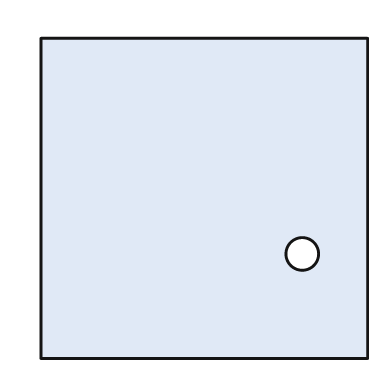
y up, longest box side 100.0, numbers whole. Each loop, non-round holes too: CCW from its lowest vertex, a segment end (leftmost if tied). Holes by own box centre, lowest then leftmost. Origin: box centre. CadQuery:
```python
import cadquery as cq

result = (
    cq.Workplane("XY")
    .moveTo(-50.0, -49.0)
    .lineTo(50.0, -49.0)
    .lineTo(50.0, 49.0)
    .lineTo(-50.0, 49.0)
    .close()
    .moveTo(30.0, -17.0)
    .circle(5.0)
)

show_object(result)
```